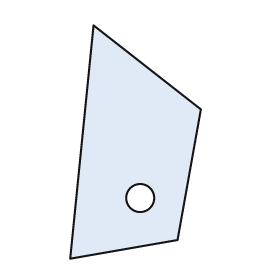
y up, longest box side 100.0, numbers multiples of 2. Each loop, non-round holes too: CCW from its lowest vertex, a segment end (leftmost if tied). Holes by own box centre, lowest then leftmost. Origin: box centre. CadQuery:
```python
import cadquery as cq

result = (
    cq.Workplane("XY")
    .moveTo(-28.0, -50.0)
    .lineTo(18.0, -42.0)
    .lineTo(28.0, 14.0)
    .lineTo(-18.0, 50.0)
    .close()
    .moveTo(2.0, -24.0)
    .circle(6.0)
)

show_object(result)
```